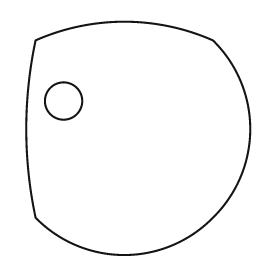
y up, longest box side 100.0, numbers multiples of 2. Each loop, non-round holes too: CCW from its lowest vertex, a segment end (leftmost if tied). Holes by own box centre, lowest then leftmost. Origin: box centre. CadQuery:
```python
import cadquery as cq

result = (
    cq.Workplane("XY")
    .moveTo(-44.0, -34.0)
    .threePointArc((-6.0, -50.0), (32.0, -34.0))
    .threePointArc((48.0, 4.0), (32.0, 42.0))
    .threePointArc((-6.0, 50.0), (-44.0, 42.0))
    .threePointArc((-48.0, 4.0), (-44.0, -34.0))
    .close()
    .moveTo(-32.0, 16.0)
    .circle(8.0)
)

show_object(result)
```